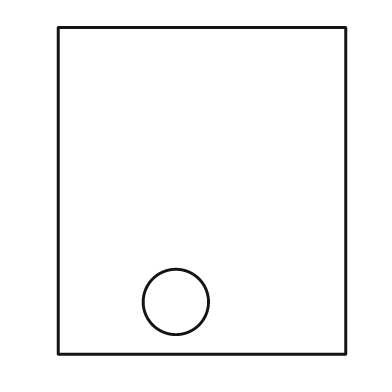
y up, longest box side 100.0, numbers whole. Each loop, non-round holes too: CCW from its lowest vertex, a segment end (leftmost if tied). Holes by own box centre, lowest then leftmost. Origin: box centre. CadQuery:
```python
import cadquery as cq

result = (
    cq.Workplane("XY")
    .moveTo(-44.0, -50.0)
    .lineTo(44.0, -50.0)
    .lineTo(44.0, 50.0)
    .lineTo(-44.0, 50.0)
    .close()
    .moveTo(-8.0, -34.0)
    .circle(10.0)
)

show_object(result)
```